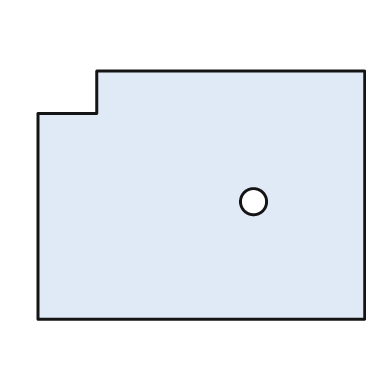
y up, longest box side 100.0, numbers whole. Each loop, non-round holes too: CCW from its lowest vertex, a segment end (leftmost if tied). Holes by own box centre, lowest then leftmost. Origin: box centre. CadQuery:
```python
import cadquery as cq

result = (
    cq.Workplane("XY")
    .moveTo(-50.0, -38.0)
    .lineTo(50.0, -38.0)
    .lineTo(50.0, 38.0)
    .lineTo(-32.0, 38.0)
    .lineTo(-32.0, 25.0)
    .lineTo(-50.0, 25.0)
    .close()
    .moveTo(16.0, -2.0)
    .circle(4.0)
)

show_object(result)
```